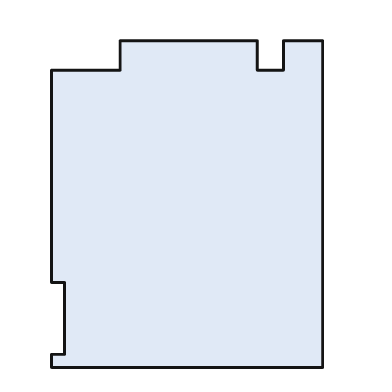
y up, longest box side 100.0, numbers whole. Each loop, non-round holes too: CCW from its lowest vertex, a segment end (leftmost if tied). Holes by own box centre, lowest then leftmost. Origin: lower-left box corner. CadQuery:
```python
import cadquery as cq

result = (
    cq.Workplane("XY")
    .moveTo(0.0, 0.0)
    .lineTo(83.0, 0.0)
    .lineTo(83.0, 100.0)
    .lineTo(71.0, 100.0)
    .lineTo(71.0, 91.0)
    .lineTo(63.0, 91.0)
    .lineTo(63.0, 100.0)
    .lineTo(21.0, 100.0)
    .lineTo(21.0, 91.0)
    .lineTo(0.0, 91.0)
    .lineTo(0.0, 26.0)
    .lineTo(4.0, 26.0)
    .lineTo(4.0, 4.0)
    .lineTo(0.0, 4.0)
    .close()
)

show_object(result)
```